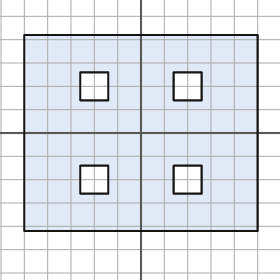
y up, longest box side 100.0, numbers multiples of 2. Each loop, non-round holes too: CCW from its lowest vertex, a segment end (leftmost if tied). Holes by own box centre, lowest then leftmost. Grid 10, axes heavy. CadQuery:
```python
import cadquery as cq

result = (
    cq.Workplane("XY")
    .moveTo(-50.0, -42.0)
    .lineTo(50.0, -42.0)
    .lineTo(50.0, 42.0)
    .lineTo(-50.0, 42.0)
    .close()
    .moveTo(-26.0, -26.0)
    .lineTo(-14.0, -26.0)
    .lineTo(-14.0, -14.0)
    .lineTo(-26.0, -14.0)
    .close()
    .moveTo(14.0, -26.0)
    .lineTo(26.0, -26.0)
    .lineTo(26.0, -14.0)
    .lineTo(14.0, -14.0)
    .close()
    .moveTo(-26.0, 14.0)
    .lineTo(-14.0, 14.0)
    .lineTo(-14.0, 26.0)
    .lineTo(-26.0, 26.0)
    .close()
    .moveTo(14.0, 14.0)
    .lineTo(26.0, 14.0)
    .lineTo(26.0, 26.0)
    .lineTo(14.0, 26.0)
    .close()
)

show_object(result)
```